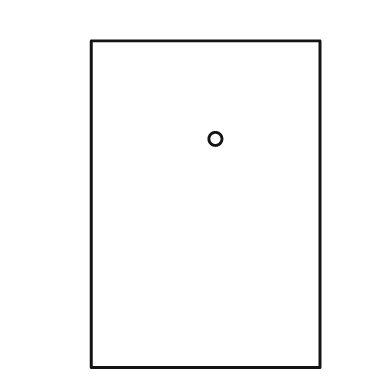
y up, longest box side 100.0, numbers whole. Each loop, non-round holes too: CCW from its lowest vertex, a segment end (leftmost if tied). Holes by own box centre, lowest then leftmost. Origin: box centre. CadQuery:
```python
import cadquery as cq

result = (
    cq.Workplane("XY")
    .moveTo(-35.0, -50.0)
    .lineTo(35.0, -50.0)
    .lineTo(35.0, 50.0)
    .lineTo(-35.0, 50.0)
    .close()
    .moveTo(3.0, 20.0)
    .circle(2.0)
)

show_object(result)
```